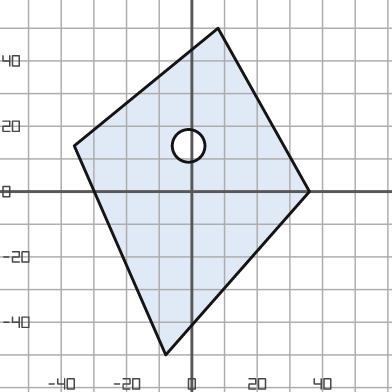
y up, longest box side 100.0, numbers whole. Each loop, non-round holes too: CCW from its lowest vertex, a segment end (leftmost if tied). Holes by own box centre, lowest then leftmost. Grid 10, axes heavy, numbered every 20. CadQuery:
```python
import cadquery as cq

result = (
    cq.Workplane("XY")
    .moveTo(-8.0, -50.0)
    .lineTo(36.0, 0.0)
    .lineTo(8.0, 50.0)
    .lineTo(-36.0, 14.0)
    .close()
    .moveTo(-1.0, 14.0)
    .circle(5.0)
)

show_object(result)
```